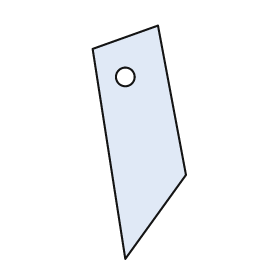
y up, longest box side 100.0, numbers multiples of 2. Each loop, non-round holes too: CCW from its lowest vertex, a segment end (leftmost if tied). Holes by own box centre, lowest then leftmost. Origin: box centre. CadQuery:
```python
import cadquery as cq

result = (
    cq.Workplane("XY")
    .moveTo(-6.0, -50.0)
    .lineTo(20.0, -14.0)
    .lineTo(8.0, 50.0)
    .lineTo(-20.0, 40.0)
    .close()
    .moveTo(-6.0, 28.0)
    .circle(4.0)
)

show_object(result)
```